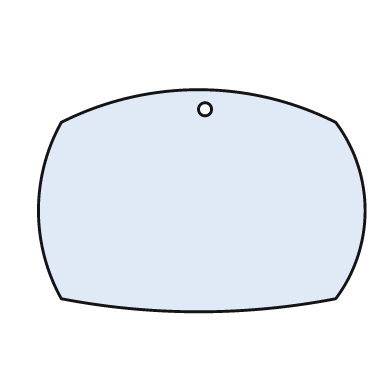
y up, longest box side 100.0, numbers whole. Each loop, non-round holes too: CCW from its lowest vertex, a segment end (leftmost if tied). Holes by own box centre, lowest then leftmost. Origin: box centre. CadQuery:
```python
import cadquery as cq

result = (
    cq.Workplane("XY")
    .moveTo(-43.0, -30.0)
    .threePointArc((-1.0, -34.0), (41.0, -30.0))
    .threePointArc((50.0, -3.0), (41.0, 24.0))
    .threePointArc((-1.0, 34.0), (-43.0, 24.0))
    .threePointArc((-50.0, -3.0), (-43.0, -30.0))
    .close()
    .moveTo(1.0, 28.0)
    .circle(2.0)
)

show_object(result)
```